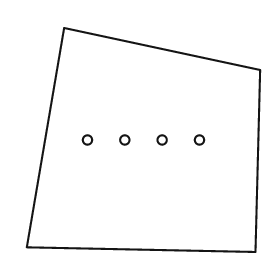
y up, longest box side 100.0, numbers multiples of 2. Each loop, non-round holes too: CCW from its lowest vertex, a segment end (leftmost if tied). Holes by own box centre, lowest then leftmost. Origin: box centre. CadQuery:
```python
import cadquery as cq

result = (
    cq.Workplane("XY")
    .moveTo(48.0, -48.0)
    .lineTo(50.0, 30.0)
    .lineTo(-34.0, 48.0)
    .lineTo(-50.0, -46.0)
    .close()
    .moveTo(-24.0, 0.0)
    .circle(2.0)
    .moveTo(-8.0, 0.0)
    .circle(2.0)
    .moveTo(8.0, 0.0)
    .circle(2.0)
    .moveTo(24.0, 0.0)
    .circle(2.0)
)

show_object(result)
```